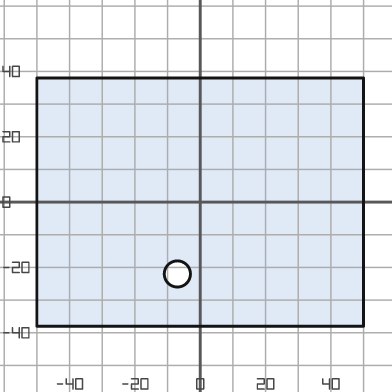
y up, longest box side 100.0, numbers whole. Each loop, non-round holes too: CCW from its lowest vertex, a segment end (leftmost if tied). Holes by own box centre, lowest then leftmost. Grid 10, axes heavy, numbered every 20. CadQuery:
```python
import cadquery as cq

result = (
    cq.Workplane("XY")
    .moveTo(-50.0, -38.0)
    .lineTo(50.0, -38.0)
    .lineTo(50.0, 38.0)
    .lineTo(-50.0, 38.0)
    .close()
    .moveTo(-7.0, -22.0)
    .circle(4.0)
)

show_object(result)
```